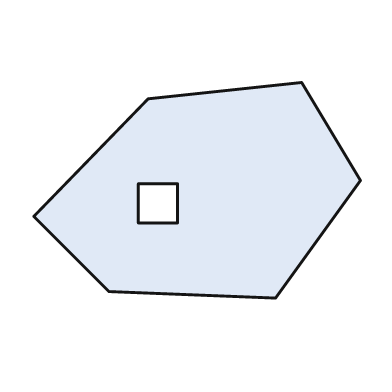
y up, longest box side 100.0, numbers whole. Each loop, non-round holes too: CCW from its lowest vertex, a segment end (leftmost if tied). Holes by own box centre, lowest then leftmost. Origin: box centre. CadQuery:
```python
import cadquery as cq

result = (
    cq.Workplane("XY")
    .moveTo(24.0, -33.0)
    .lineTo(50.0, 3.0)
    .lineTo(32.0, 33.0)
    .lineTo(-15.0, 28.0)
    .lineTo(-50.0, -8.0)
    .lineTo(-27.0, -31.0)
    .close()
    .moveTo(-18.0, -10.0)
    .lineTo(-6.0, -10.0)
    .lineTo(-6.0, 2.0)
    .lineTo(-18.0, 2.0)
    .close()
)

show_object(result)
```